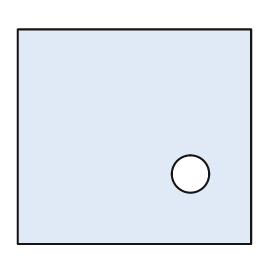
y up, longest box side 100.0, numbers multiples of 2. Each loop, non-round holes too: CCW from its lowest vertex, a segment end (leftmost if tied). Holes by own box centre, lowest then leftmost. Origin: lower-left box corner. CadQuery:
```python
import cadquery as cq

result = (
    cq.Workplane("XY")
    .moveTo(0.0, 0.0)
    .lineTo(100.0, 0.0)
    .lineTo(100.0, 92.0)
    .lineTo(0.0, 92.0)
    .close()
    .moveTo(74.0, 30.0)
    .circle(8.0)
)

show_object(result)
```